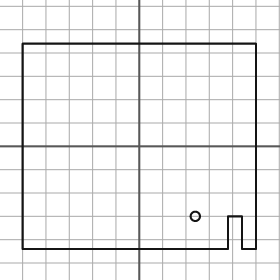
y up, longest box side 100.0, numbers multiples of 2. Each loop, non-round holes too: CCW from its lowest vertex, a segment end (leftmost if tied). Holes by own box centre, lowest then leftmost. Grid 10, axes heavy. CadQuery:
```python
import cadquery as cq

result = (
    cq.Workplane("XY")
    .moveTo(-50.0, -44.0)
    .lineTo(38.0, -44.0)
    .lineTo(38.0, -30.0)
    .lineTo(44.0, -30.0)
    .lineTo(44.0, -44.0)
    .lineTo(50.0, -44.0)
    .lineTo(50.0, 44.0)
    .lineTo(-50.0, 44.0)
    .close()
    .moveTo(24.0, -30.0)
    .circle(2.0)
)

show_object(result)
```